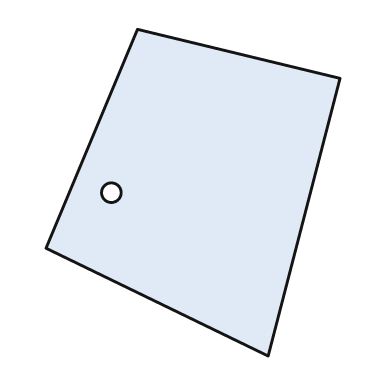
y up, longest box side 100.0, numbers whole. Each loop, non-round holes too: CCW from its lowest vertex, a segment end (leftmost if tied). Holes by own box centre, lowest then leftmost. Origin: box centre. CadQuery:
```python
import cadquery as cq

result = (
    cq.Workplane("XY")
    .moveTo(23.0, -50.0)
    .lineTo(45.0, 35.0)
    .lineTo(-17.0, 50.0)
    .lineTo(-45.0, -17.0)
    .close()
    .moveTo(-25.0, 0.0)
    .circle(3.0)
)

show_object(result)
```